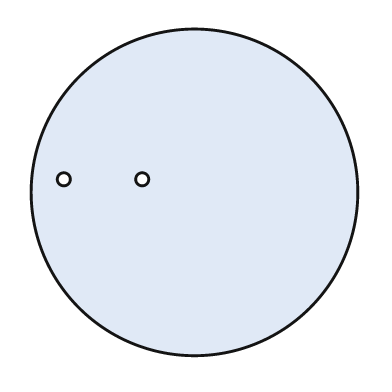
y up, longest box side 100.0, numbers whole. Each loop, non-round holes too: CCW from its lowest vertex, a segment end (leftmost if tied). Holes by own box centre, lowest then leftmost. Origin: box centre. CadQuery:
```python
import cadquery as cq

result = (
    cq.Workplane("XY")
    .moveTo(0.0, 0.0)
    .circle(50.0)
    .moveTo(-40.0, 4.0)
    .circle(2.0)
    .moveTo(-16.0, 4.0)
    .circle(2.0)
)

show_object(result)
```